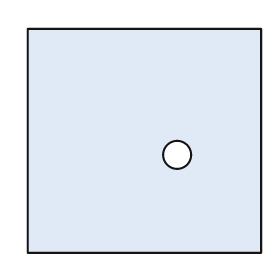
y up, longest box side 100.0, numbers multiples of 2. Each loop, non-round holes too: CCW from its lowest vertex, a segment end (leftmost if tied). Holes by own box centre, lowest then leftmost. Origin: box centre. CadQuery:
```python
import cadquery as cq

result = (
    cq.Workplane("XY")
    .moveTo(-50.0, -48.0)
    .lineTo(50.0, -48.0)
    .lineTo(50.0, 48.0)
    .lineTo(-50.0, 48.0)
    .close()
    .moveTo(14.0, -6.0)
    .circle(6.0)
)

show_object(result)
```